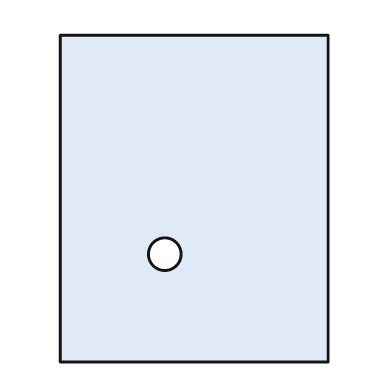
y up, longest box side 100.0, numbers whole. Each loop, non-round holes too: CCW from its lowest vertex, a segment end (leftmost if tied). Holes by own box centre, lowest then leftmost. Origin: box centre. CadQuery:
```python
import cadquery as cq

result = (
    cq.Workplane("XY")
    .moveTo(-41.0, -50.0)
    .lineTo(41.0, -50.0)
    .lineTo(41.0, 50.0)
    .lineTo(-41.0, 50.0)
    .close()
    .moveTo(-9.0, -17.0)
    .circle(5.0)
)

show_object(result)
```